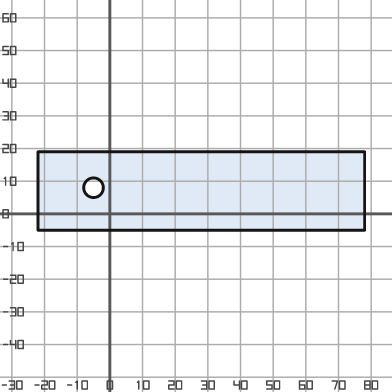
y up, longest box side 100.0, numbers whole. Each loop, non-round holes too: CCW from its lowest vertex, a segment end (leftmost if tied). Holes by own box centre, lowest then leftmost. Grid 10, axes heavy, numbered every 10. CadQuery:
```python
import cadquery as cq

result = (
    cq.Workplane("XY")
    .moveTo(-22.0, -5.0)
    .lineTo(78.0, -5.0)
    .lineTo(78.0, 19.0)
    .lineTo(-22.0, 19.0)
    .close()
    .moveTo(-5.0, 8.0)
    .circle(3.0)
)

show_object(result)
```